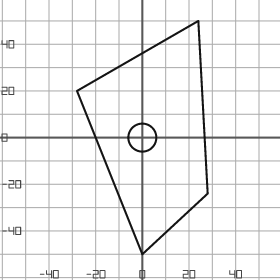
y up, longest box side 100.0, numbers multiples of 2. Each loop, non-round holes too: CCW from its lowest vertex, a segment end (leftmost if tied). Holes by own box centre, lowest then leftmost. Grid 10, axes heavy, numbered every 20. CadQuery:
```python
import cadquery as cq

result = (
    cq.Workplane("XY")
    .moveTo(0.0, -50.0)
    .lineTo(28.0, -24.0)
    .lineTo(24.0, 50.0)
    .lineTo(-28.0, 20.0)
    .close()
    .moveTo(0.0, 0.0)
    .circle(6.0)
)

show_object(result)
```